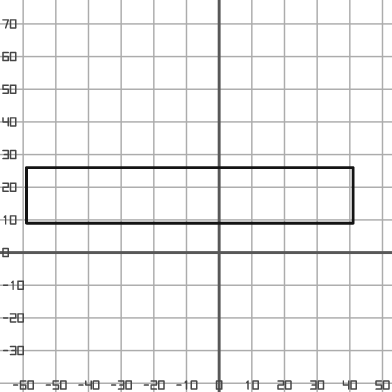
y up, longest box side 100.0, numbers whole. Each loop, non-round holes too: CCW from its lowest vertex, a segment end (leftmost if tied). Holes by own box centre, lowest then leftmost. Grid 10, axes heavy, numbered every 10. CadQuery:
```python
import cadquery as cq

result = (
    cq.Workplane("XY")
    .moveTo(-59.0, 9.0)
    .lineTo(41.0, 9.0)
    .lineTo(41.0, 26.0)
    .lineTo(-59.0, 26.0)
    .close()
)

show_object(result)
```